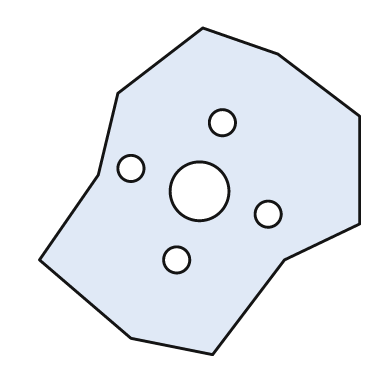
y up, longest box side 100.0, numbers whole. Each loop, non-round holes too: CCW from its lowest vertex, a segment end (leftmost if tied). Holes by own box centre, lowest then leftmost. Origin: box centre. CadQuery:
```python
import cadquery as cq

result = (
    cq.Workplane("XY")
    .moveTo(4.0, -50.0)
    .lineTo(26.0, -21.0)
    .lineTo(49.0, -10.0)
    .lineTo(49.0, 23.0)
    .lineTo(24.0, 42.0)
    .lineTo(1.0, 50.0)
    .lineTo(-25.0, 30.0)
    .lineTo(-31.0, 5.0)
    .lineTo(-49.0, -21.0)
    .lineTo(-21.0, -45.0)
    .close()
    .moveTo(-7.0, -21.0)
    .circle(4.0)
    .moveTo(21.0, -7.0)
    .circle(4.0)
    .moveTo(0.0, 0.0)
    .circle(9.0)
    .moveTo(-21.0, 7.0)
    .circle(4.0)
    .moveTo(7.0, 21.0)
    .circle(4.0)
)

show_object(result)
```